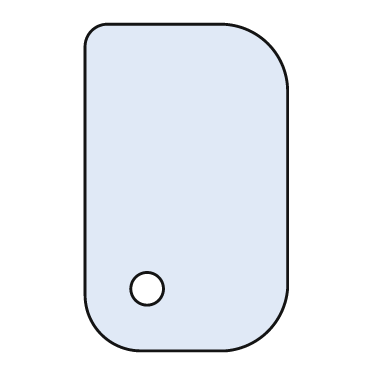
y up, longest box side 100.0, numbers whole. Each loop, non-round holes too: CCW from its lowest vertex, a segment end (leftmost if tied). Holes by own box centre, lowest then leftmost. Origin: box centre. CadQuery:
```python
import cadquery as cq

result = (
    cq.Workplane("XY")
    .moveTo(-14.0, -50.0)
    .lineTo(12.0, -50.0)
    .threePointArc((25.0, -44.0), (31.0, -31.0))
    .lineTo(31.0, 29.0)
    .threePointArc((25.0, 44.0), (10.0, 50.0))
    .lineTo(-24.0, 50.0)
    .threePointArc((-29.0, 48.0), (-31.0, 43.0))
    .lineTo(-31.0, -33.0)
    .threePointArc((-26.0, -45.0), (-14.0, -50.0))
    .close()
    .moveTo(-12.0, -31.0)
    .circle(5.0)
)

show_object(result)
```